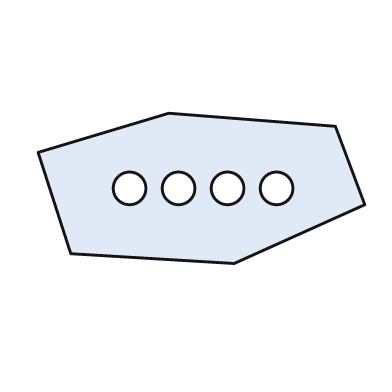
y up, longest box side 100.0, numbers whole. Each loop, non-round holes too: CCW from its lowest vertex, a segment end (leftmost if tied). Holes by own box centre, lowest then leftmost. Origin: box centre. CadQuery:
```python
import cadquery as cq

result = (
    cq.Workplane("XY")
    .moveTo(10.0, -23.0)
    .lineTo(50.0, -5.0)
    .lineTo(41.0, 19.0)
    .lineTo(-10.0, 23.0)
    .lineTo(-50.0, 11.0)
    .lineTo(-40.0, -20.0)
    .close()
    .moveTo(-22.0, 0.0)
    .circle(5.0)
    .moveTo(-7.0, 0.0)
    .circle(5.0)
    .moveTo(8.0, 0.0)
    .circle(5.0)
    .moveTo(23.0, 0.0)
    .circle(5.0)
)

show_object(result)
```